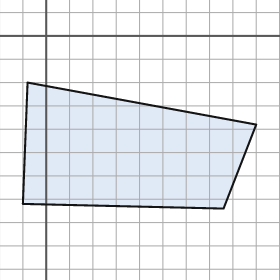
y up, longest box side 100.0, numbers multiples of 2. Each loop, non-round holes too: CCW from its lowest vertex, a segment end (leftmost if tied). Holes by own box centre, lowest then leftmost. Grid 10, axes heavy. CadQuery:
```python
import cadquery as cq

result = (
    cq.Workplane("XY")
    .moveTo(76.0, -74.0)
    .lineTo(90.0, -38.0)
    .lineTo(-8.0, -20.0)
    .lineTo(-10.0, -72.0)
    .close()
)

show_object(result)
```